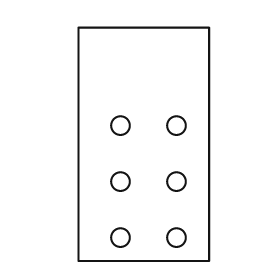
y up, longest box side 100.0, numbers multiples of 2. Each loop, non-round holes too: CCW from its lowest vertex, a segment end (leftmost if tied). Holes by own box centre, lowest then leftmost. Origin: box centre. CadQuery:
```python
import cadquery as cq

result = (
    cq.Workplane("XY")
    .moveTo(-28.0, -50.0)
    .lineTo(28.0, -50.0)
    .lineTo(28.0, 50.0)
    .lineTo(-28.0, 50.0)
    .close()
    .moveTo(-10.0, -40.0)
    .circle(4.0)
    .moveTo(14.0, -40.0)
    .circle(4.0)
    .moveTo(-10.0, -16.0)
    .circle(4.0)
    .moveTo(14.0, -16.0)
    .circle(4.0)
    .moveTo(-10.0, 8.0)
    .circle(4.0)
    .moveTo(14.0, 8.0)
    .circle(4.0)
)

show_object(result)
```